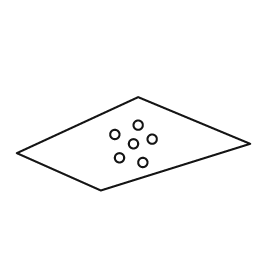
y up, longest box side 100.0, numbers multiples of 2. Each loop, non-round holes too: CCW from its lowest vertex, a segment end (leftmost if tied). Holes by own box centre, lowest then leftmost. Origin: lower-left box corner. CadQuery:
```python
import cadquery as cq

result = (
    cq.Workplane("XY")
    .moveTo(36.0, 0.0)
    .lineTo(100.0, 20.0)
    .lineTo(52.0, 40.0)
    .lineTo(0.0, 16.0)
    .close()
    .moveTo(54.0, 12.0)
    .circle(2.0)
    .moveTo(44.0, 14.0)
    .circle(2.0)
    .moveTo(50.0, 20.0)
    .circle(2.0)
    .moveTo(58.0, 22.0)
    .circle(2.0)
    .moveTo(42.0, 24.0)
    .circle(2.0)
    .moveTo(52.0, 28.0)
    .circle(2.0)
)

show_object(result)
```